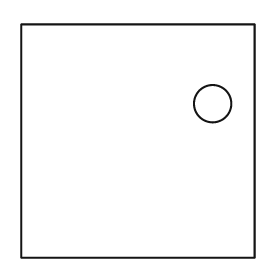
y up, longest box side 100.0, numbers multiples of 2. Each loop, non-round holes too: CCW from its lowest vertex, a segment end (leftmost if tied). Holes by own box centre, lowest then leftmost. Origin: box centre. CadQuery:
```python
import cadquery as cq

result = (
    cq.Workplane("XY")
    .moveTo(-50.0, -50.0)
    .lineTo(50.0, -50.0)
    .lineTo(50.0, 50.0)
    .lineTo(-50.0, 50.0)
    .close()
    .moveTo(32.0, 16.0)
    .circle(8.0)
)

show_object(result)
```